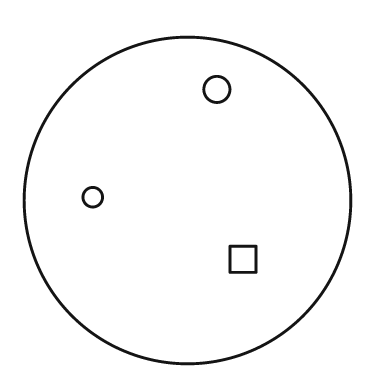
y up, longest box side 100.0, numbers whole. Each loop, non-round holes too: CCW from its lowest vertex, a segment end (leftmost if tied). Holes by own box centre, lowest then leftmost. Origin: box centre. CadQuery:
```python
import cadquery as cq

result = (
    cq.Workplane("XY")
    .moveTo(0.0, 0.0)
    .circle(50.0)
    .moveTo(13.0, -22.0)
    .lineTo(21.0, -22.0)
    .lineTo(21.0, -14.0)
    .lineTo(13.0, -14.0)
    .close()
    .moveTo(-29.0, 1.0)
    .circle(3.0)
    .moveTo(9.0, 34.0)
    .circle(4.0)
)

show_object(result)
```